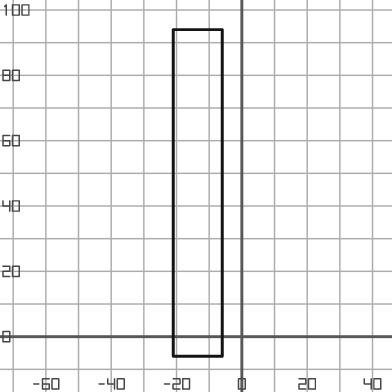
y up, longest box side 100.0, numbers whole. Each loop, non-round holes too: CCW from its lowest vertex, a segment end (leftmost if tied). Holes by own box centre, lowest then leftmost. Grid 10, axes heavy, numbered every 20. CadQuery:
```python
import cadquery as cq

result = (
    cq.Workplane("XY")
    .moveTo(-21.0, -6.0)
    .lineTo(-6.0, -6.0)
    .lineTo(-6.0, 94.0)
    .lineTo(-21.0, 94.0)
    .close()
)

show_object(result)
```